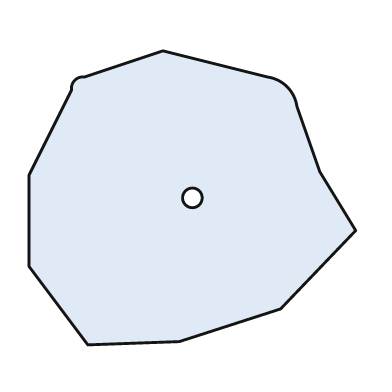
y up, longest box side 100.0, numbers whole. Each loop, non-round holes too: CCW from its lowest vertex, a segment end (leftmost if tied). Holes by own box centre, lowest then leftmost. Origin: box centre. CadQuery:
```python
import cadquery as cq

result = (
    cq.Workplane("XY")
    .moveTo(-32.0, -45.0)
    .lineTo(-4.0, -44.0)
    .lineTo(27.0, -34.0)
    .lineTo(50.0, -10.0)
    .lineTo(39.0, 8.0)
    .lineTo(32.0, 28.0)
    .threePointArc((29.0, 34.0), (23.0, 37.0))
    .lineTo(-9.0, 45.0)
    .lineTo(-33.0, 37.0)
    .threePointArc((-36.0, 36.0), (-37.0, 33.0))
    .lineTo(-50.0, 7.0)
    .lineTo(-50.0, -21.0)
    .close()
    .moveTo(0.0, 0.0)
    .circle(3.0)
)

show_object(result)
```